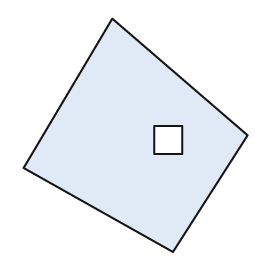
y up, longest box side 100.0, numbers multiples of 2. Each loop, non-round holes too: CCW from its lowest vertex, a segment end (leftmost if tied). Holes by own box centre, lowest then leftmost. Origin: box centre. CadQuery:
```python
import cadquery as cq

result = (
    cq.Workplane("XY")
    .moveTo(16.0, -50.0)
    .lineTo(48.0, 0.0)
    .lineTo(-10.0, 50.0)
    .lineTo(-48.0, -14.0)
    .close()
    .moveTo(8.0, -8.0)
    .lineTo(20.0, -8.0)
    .lineTo(20.0, 4.0)
    .lineTo(8.0, 4.0)
    .close()
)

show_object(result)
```